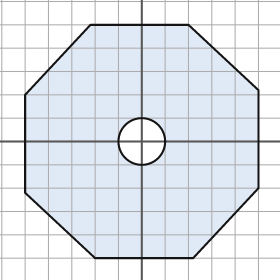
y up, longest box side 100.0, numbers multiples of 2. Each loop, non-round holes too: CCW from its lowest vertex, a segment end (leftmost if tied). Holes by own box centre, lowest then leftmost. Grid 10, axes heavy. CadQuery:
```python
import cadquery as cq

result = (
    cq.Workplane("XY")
    .moveTo(-20.0, -50.0)
    .lineTo(22.0, -50.0)
    .lineTo(50.0, -20.0)
    .lineTo(50.0, 22.0)
    .lineTo(20.0, 50.0)
    .lineTo(-22.0, 50.0)
    .lineTo(-50.0, 20.0)
    .lineTo(-50.0, -22.0)
    .close()
    .moveTo(0.0, 0.0)
    .circle(10.0)
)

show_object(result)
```